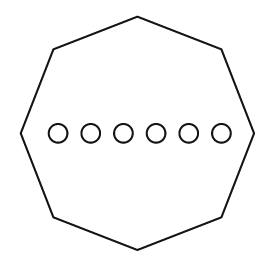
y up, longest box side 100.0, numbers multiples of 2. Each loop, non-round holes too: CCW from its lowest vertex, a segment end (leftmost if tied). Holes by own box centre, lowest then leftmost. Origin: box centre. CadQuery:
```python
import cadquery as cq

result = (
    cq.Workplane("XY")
    .moveTo(0.0, -50.0)
    .lineTo(36.0, -36.0)
    .lineTo(50.0, 0.0)
    .lineTo(36.0, 36.0)
    .lineTo(0.0, 50.0)
    .lineTo(-36.0, 36.0)
    .lineTo(-50.0, 0.0)
    .lineTo(-36.0, -36.0)
    .close()
    .moveTo(-34.0, 0.0)
    .circle(4.0)
    .moveTo(-20.0, 0.0)
    .circle(4.0)
    .moveTo(-6.0, 0.0)
    .circle(4.0)
    .moveTo(8.0, 0.0)
    .circle(4.0)
    .moveTo(22.0, 0.0)
    .circle(4.0)
    .moveTo(36.0, 0.0)
    .circle(4.0)
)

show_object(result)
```